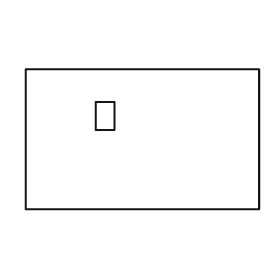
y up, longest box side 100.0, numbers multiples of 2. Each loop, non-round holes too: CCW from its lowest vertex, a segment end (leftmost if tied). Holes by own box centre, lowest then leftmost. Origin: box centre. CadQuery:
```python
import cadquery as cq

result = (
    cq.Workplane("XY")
    .moveTo(-50.0, -30.0)
    .lineTo(50.0, -30.0)
    .lineTo(50.0, 30.0)
    .lineTo(-50.0, 30.0)
    .close()
    .moveTo(-20.0, 4.0)
    .lineTo(-12.0, 4.0)
    .lineTo(-12.0, 16.0)
    .lineTo(-20.0, 16.0)
    .close()
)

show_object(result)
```